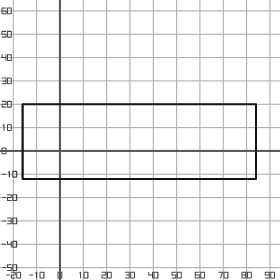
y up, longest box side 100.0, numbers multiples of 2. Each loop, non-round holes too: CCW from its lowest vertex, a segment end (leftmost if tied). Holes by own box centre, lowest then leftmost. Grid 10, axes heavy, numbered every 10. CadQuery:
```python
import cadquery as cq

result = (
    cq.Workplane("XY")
    .moveTo(-16.0, -12.0)
    .lineTo(84.0, -12.0)
    .lineTo(84.0, 20.0)
    .lineTo(-16.0, 20.0)
    .close()
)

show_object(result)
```